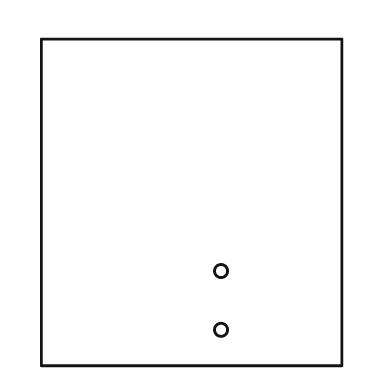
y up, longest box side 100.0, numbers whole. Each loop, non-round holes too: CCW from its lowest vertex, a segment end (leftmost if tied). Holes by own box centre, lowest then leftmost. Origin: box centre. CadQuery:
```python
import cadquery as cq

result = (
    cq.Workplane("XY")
    .moveTo(-46.0, -50.0)
    .lineTo(46.0, -50.0)
    .lineTo(46.0, 50.0)
    .lineTo(-46.0, 50.0)
    .close()
    .moveTo(9.0, -39.0)
    .circle(2.0)
    .moveTo(9.0, -21.0)
    .circle(2.0)
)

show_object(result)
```